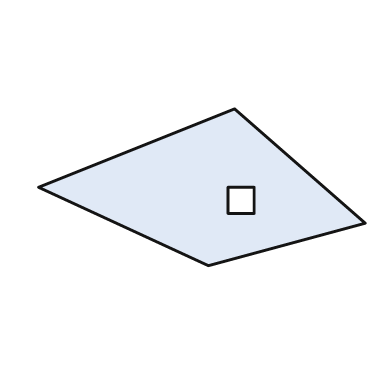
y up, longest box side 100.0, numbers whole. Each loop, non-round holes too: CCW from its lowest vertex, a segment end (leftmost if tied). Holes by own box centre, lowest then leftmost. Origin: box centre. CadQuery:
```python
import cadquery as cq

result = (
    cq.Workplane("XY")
    .moveTo(2.0, -24.0)
    .lineTo(50.0, -11.0)
    .lineTo(10.0, 24.0)
    .lineTo(-50.0, 0.0)
    .close()
    .moveTo(8.0, -8.0)
    .lineTo(16.0, -8.0)
    .lineTo(16.0, 0.0)
    .lineTo(8.0, 0.0)
    .close()
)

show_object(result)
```